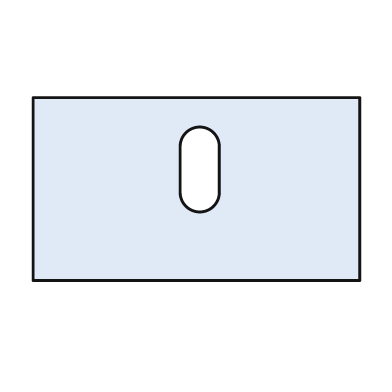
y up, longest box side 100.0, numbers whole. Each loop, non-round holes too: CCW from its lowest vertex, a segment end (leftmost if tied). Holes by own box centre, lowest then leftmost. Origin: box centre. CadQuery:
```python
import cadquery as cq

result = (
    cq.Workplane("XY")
    .moveTo(-50.0, -28.0)
    .lineTo(50.0, -28.0)
    .lineTo(50.0, 28.0)
    .lineTo(-50.0, 28.0)
    .close()
    .moveTo(-5.0, -1.0)
    .threePointArc((1.0, -7.0), (7.0, -1.0))
    .lineTo(7.0, 13.0)
    .threePointArc((1.0, 19.0), (-5.0, 13.0))
    .close()
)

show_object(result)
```